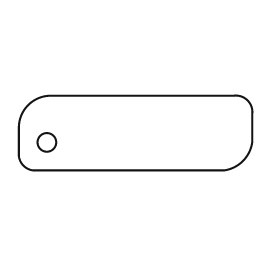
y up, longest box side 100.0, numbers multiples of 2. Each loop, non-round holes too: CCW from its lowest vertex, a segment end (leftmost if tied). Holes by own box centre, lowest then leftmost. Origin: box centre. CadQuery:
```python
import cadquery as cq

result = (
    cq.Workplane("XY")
    .moveTo(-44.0, -16.0)
    .lineTo(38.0, -16.0)
    .threePointArc((46.0, -12.0), (50.0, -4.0))
    .lineTo(50.0, 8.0)
    .threePointArc((48.0, 14.0), (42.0, 16.0))
    .lineTo(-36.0, 16.0)
    .threePointArc((-46.0, 12.0), (-50.0, 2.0))
    .lineTo(-50.0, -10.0)
    .threePointArc((-48.0, -14.0), (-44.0, -16.0))
    .close()
    .moveTo(-38.0, -4.0)
    .circle(4.0)
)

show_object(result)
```